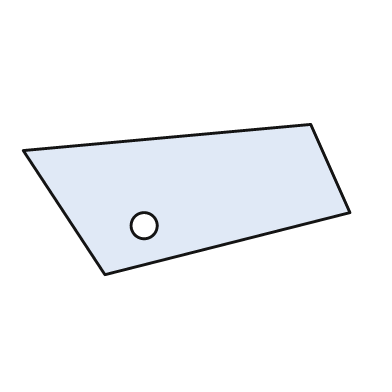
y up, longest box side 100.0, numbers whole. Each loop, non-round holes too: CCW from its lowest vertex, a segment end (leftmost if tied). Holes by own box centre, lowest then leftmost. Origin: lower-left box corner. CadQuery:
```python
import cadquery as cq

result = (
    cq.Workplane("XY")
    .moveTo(25.0, 0.0)
    .lineTo(100.0, 19.0)
    .lineTo(88.0, 46.0)
    .lineTo(0.0, 38.0)
    .close()
    .moveTo(37.0, 15.0)
    .circle(4.0)
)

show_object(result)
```